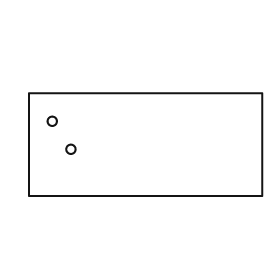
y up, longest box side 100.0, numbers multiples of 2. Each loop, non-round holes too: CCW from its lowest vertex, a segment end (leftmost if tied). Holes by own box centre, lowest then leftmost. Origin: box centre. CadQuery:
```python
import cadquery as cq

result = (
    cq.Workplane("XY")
    .moveTo(-50.0, -22.0)
    .lineTo(50.0, -22.0)
    .lineTo(50.0, 22.0)
    .lineTo(-50.0, 22.0)
    .close()
    .moveTo(-32.0, -2.0)
    .circle(2.0)
    .moveTo(-40.0, 10.0)
    .circle(2.0)
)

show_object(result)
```